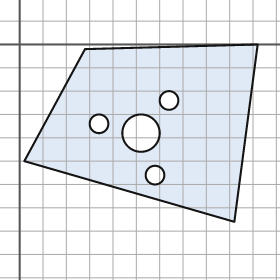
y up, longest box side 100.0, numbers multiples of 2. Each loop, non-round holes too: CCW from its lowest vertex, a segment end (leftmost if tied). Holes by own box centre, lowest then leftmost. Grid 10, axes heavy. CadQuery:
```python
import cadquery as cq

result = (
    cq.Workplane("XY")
    .moveTo(92.0, -76.0)
    .lineTo(102.0, 0.0)
    .lineTo(28.0, -2.0)
    .lineTo(2.0, -50.0)
    .close()
    .moveTo(58.0, -56.0)
    .circle(4.0)
    .moveTo(52.0, -38.0)
    .circle(8.0)
    .moveTo(34.0, -34.0)
    .circle(4.0)
    .moveTo(64.0, -24.0)
    .circle(4.0)
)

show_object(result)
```